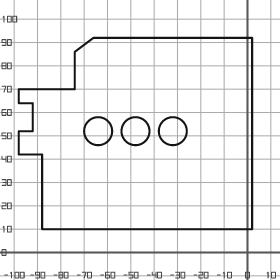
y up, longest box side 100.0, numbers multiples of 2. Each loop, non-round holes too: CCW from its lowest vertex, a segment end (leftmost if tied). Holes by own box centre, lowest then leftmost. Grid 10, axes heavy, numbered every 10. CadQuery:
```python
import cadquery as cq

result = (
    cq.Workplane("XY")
    .moveTo(-88.0, 10.0)
    .lineTo(2.0, 10.0)
    .lineTo(2.0, 92.0)
    .lineTo(-66.0, 92.0)
    .lineTo(-74.0, 86.0)
    .lineTo(-74.0, 70.0)
    .lineTo(-98.0, 70.0)
    .lineTo(-98.0, 64.0)
    .lineTo(-92.0, 64.0)
    .lineTo(-92.0, 52.0)
    .lineTo(-98.0, 52.0)
    .lineTo(-98.0, 42.0)
    .lineTo(-88.0, 42.0)
    .close()
    .moveTo(-64.0, 52.0)
    .circle(6.0)
    .moveTo(-48.0, 52.0)
    .circle(6.0)
    .moveTo(-32.0, 52.0)
    .circle(6.0)
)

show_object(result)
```